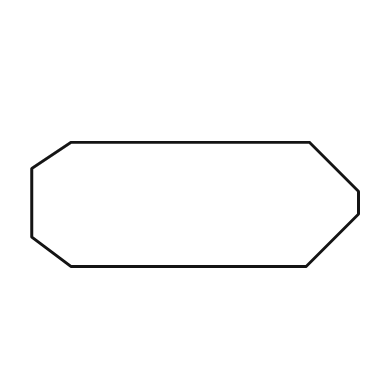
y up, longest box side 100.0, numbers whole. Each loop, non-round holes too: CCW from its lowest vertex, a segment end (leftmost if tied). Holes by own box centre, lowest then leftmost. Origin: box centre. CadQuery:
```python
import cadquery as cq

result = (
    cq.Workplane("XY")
    .moveTo(-38.0, -19.0)
    .lineTo(34.0, -19.0)
    .lineTo(50.0, -3.0)
    .lineTo(50.0, 4.0)
    .lineTo(35.0, 19.0)
    .lineTo(-38.0, 19.0)
    .lineTo(-50.0, 11.0)
    .lineTo(-50.0, -10.0)
    .close()
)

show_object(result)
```